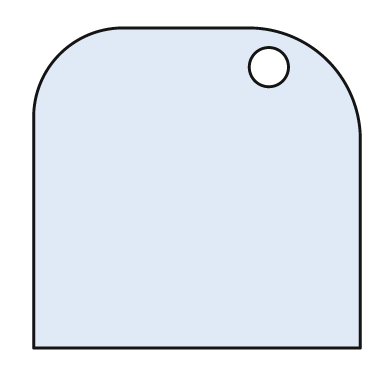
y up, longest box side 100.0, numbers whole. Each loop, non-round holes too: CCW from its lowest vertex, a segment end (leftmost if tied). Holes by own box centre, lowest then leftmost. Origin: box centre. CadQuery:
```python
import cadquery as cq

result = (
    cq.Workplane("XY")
    .moveTo(-50.0, -49.0)
    .lineTo(50.0, -49.0)
    .lineTo(50.0, 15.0)
    .threePointArc((40.0, 39.0), (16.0, 49.0))
    .lineTo(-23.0, 49.0)
    .threePointArc((-42.0, 41.0), (-50.0, 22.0))
    .close()
    .moveTo(22.0, 37.0)
    .circle(6.0)
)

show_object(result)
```